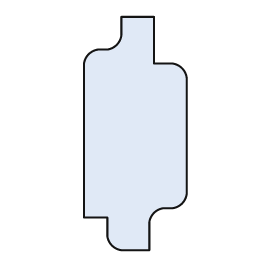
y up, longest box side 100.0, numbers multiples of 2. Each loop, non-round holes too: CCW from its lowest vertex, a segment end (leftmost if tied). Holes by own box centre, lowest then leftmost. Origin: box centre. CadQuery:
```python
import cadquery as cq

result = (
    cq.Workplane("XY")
    .moveTo(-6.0, -50.0)
    .lineTo(6.0, -50.0)
    .lineTo(6.0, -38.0)
    .threePointArc((8.0, -34.0), (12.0, -32.0))
    .lineTo(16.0, -32.0)
    .threePointArc((20.0, -30.0), (22.0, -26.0))
    .lineTo(22.0, 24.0)
    .threePointArc((20.0, 28.0), (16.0, 30.0))
    .lineTo(8.0, 30.0)
    .lineTo(8.0, 50.0)
    .lineTo(-6.0, 50.0)
    .lineTo(-6.0, 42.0)
    .threePointArc((-8.0, 38.0), (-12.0, 36.0))
    .lineTo(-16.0, 36.0)
    .threePointArc((-20.0, 34.0), (-22.0, 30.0))
    .lineTo(-22.0, -36.0)
    .lineTo(-12.0, -36.0)
    .lineTo(-12.0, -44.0)
    .threePointArc((-10.0, -48.0), (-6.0, -50.0))
    .close()
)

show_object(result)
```